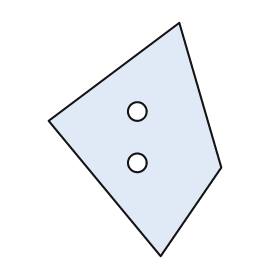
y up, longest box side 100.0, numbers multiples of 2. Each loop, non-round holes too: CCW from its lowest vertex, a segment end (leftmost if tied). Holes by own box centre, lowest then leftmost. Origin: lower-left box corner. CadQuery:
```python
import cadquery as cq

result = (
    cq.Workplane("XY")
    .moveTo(48.0, 0.0)
    .lineTo(74.0, 38.0)
    .lineTo(56.0, 100.0)
    .lineTo(0.0, 58.0)
    .close()
    .moveTo(38.0, 40.0)
    .circle(4.0)
    .moveTo(38.0, 62.0)
    .circle(4.0)
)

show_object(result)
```